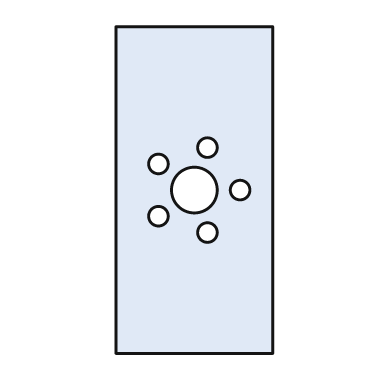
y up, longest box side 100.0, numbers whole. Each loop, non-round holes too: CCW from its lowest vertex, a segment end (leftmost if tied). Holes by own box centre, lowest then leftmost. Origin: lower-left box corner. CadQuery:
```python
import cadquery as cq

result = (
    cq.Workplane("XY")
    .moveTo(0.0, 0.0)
    .lineTo(48.0, 0.0)
    .lineTo(48.0, 100.0)
    .lineTo(0.0, 100.0)
    .close()
    .moveTo(28.0, 37.0)
    .circle(3.0)
    .moveTo(13.0, 42.0)
    .circle(3.0)
    .moveTo(24.0, 50.0)
    .circle(7.0)
    .moveTo(38.0, 50.0)
    .circle(3.0)
    .moveTo(13.0, 58.0)
    .circle(3.0)
    .moveTo(28.0, 63.0)
    .circle(3.0)
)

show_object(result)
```